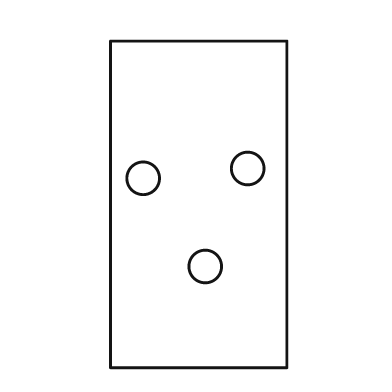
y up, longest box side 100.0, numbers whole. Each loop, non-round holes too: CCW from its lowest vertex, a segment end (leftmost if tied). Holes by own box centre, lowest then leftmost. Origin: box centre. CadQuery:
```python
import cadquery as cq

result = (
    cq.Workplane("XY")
    .moveTo(-27.0, -50.0)
    .lineTo(27.0, -50.0)
    .lineTo(27.0, 50.0)
    .lineTo(-27.0, 50.0)
    .close()
    .moveTo(2.0, -19.0)
    .circle(5.0)
    .moveTo(-17.0, 8.0)
    .circle(5.0)
    .moveTo(15.0, 11.0)
    .circle(5.0)
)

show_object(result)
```